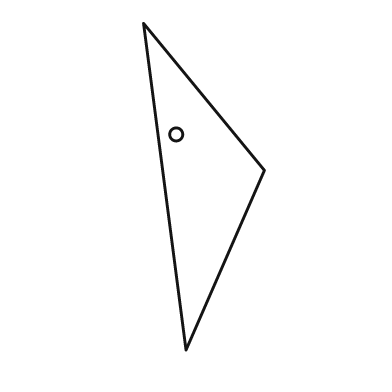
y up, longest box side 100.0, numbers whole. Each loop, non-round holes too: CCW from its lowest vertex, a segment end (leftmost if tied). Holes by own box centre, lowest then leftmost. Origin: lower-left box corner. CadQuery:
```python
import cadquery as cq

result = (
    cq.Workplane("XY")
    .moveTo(13.0, 0.0)
    .lineTo(37.0, 55.0)
    .lineTo(0.0, 100.0)
    .close()
    .moveTo(10.0, 66.0)
    .circle(2.0)
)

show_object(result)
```